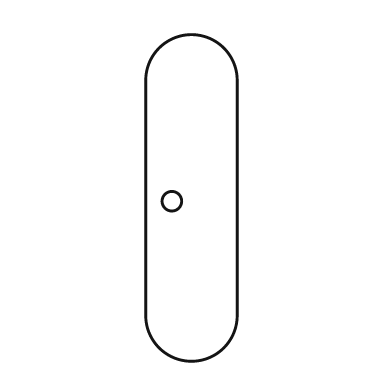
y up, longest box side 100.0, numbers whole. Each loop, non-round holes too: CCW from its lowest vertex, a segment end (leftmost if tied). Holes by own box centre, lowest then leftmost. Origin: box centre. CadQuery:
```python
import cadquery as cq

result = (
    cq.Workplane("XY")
    .moveTo(-14.0, -36.0)
    .threePointArc((0.0, -50.0), (14.0, -36.0))
    .lineTo(14.0, 36.0)
    .threePointArc((0.0, 50.0), (-14.0, 36.0))
    .close()
    .moveTo(-6.0, -1.0)
    .circle(3.0)
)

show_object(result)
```